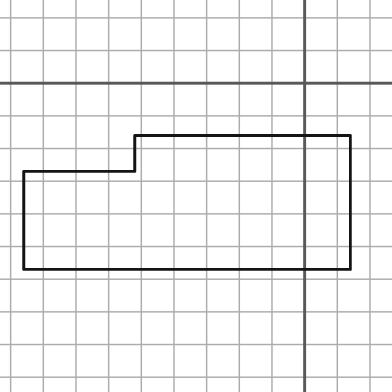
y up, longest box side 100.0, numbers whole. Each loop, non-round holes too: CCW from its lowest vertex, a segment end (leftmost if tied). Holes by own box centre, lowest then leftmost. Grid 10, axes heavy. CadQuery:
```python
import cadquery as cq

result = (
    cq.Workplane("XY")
    .moveTo(-86.0, -57.0)
    .lineTo(14.0, -57.0)
    .lineTo(14.0, -16.0)
    .lineTo(-52.0, -16.0)
    .lineTo(-52.0, -27.0)
    .lineTo(-86.0, -27.0)
    .close()
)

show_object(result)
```